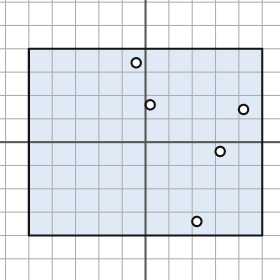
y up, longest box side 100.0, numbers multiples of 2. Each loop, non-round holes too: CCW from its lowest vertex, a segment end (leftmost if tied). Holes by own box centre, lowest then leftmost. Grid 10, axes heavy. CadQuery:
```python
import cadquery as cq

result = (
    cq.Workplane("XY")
    .moveTo(-50.0, -40.0)
    .lineTo(50.0, -40.0)
    .lineTo(50.0, 40.0)
    .lineTo(-50.0, 40.0)
    .close()
    .moveTo(22.0, -34.0)
    .circle(2.0)
    .moveTo(32.0, -4.0)
    .circle(2.0)
    .moveTo(42.0, 14.0)
    .circle(2.0)
    .moveTo(2.0, 16.0)
    .circle(2.0)
    .moveTo(-4.0, 34.0)
    .circle(2.0)
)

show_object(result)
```